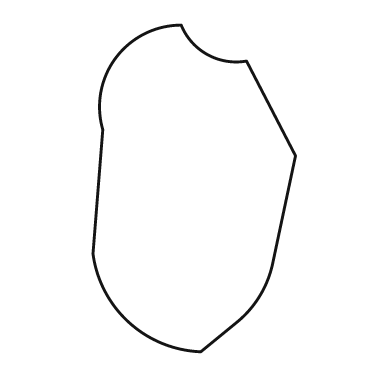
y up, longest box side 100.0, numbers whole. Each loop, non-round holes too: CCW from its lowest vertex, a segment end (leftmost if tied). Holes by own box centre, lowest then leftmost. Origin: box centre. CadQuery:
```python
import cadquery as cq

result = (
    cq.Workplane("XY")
    .moveTo(2.0, -50.0)
    .lineTo(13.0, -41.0)
    .threePointArc((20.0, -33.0), (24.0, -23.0))
    .lineTo(31.0, 10.0)
    .lineTo(16.0, 39.0)
    .threePointArc((4.0, 41.0), (-4.0, 50.0))
    .threePointArc((-24.0, 40.0), (-28.0, 18.0))
    .lineTo(-31.0, -20.0)
    .threePointArc((-20.0, -41.0), (2.0, -50.0))
    .close()
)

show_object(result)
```